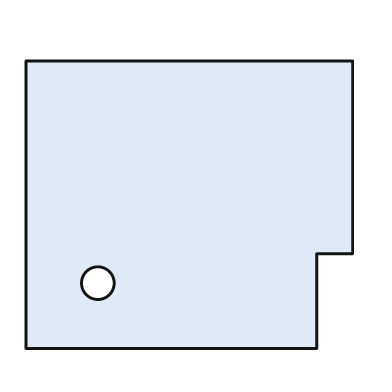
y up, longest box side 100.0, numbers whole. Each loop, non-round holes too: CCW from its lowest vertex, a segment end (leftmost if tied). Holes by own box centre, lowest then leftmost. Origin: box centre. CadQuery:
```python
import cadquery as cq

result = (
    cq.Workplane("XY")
    .moveTo(-50.0, -44.0)
    .lineTo(39.0, -44.0)
    .lineTo(39.0, -15.0)
    .lineTo(50.0, -15.0)
    .lineTo(50.0, 44.0)
    .lineTo(-50.0, 44.0)
    .close()
    .moveTo(-28.0, -24.0)
    .circle(5.0)
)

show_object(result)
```